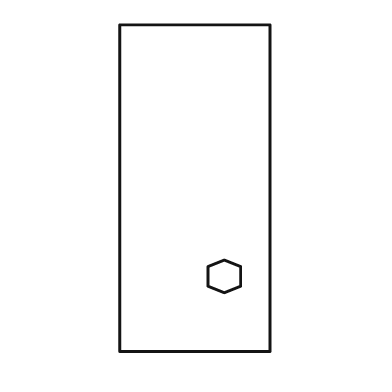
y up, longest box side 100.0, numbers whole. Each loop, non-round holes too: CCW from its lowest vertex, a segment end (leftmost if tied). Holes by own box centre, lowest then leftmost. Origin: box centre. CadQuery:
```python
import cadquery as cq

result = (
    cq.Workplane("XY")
    .moveTo(-23.0, -50.0)
    .lineTo(23.0, -50.0)
    .lineTo(23.0, 50.0)
    .lineTo(-23.0, 50.0)
    .close()
    .moveTo(9.0, -32.0)
    .lineTo(14.0, -30.0)
    .lineTo(14.0, -24.0)
    .lineTo(9.0, -22.0)
    .lineTo(4.0, -24.0)
    .lineTo(4.0, -30.0)
    .close()
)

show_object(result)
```